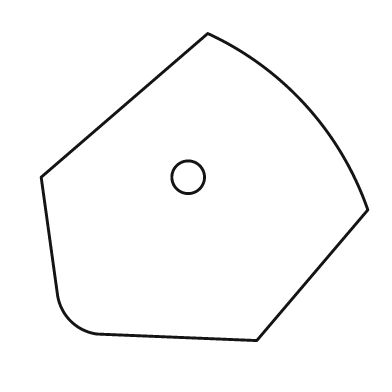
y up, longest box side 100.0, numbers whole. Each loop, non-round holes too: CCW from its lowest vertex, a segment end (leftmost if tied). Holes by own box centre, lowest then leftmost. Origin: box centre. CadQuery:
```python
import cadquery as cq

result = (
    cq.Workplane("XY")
    .moveTo(16.0, -47.0)
    .lineTo(50.0, -7.0)
    .threePointArc((31.0, 25.0), (1.0, 47.0))
    .lineTo(-50.0, 3.0)
    .lineTo(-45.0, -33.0)
    .threePointArc((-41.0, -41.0), (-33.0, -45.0))
    .close()
    .moveTo(-5.0, 3.0)
    .circle(5.0)
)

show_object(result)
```